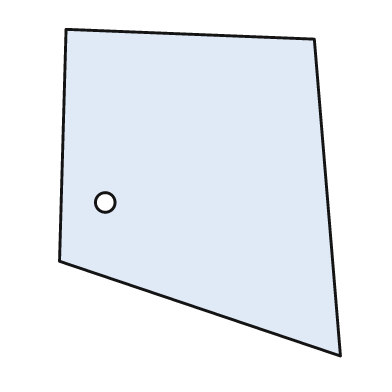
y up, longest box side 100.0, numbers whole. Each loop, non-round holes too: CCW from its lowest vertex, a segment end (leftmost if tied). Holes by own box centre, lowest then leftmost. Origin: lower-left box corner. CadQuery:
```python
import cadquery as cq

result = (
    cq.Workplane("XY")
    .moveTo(86.0, 0.0)
    .lineTo(78.0, 97.0)
    .lineTo(2.0, 100.0)
    .lineTo(0.0, 29.0)
    .close()
    .moveTo(14.0, 47.0)
    .circle(3.0)
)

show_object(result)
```